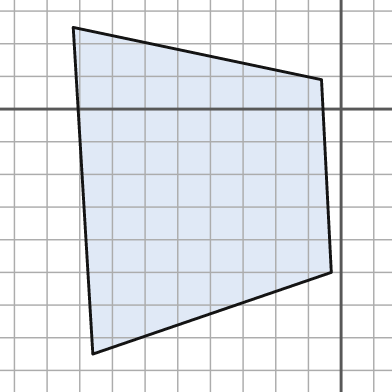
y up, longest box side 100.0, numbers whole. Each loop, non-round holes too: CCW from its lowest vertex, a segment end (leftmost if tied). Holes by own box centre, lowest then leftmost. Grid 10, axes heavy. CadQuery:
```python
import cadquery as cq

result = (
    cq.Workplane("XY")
    .moveTo(-76.0, -75.0)
    .lineTo(-3.0, -50.0)
    .lineTo(-6.0, 9.0)
    .lineTo(-82.0, 25.0)
    .close()
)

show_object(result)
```